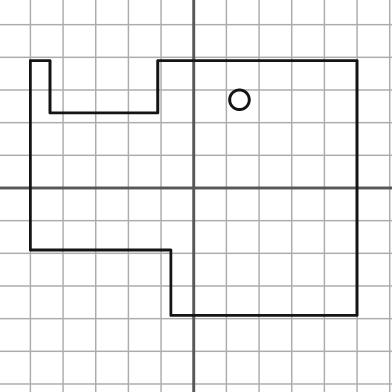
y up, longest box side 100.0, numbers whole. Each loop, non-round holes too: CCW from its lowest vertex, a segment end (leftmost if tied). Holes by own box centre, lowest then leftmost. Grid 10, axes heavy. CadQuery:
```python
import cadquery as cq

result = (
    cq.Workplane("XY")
    .moveTo(-7.0, -39.0)
    .lineTo(50.0, -39.0)
    .lineTo(50.0, 39.0)
    .lineTo(-11.0, 39.0)
    .lineTo(-11.0, 23.0)
    .lineTo(-44.0, 23.0)
    .lineTo(-44.0, 39.0)
    .lineTo(-50.0, 39.0)
    .lineTo(-50.0, -19.0)
    .lineTo(-7.0, -19.0)
    .close()
    .moveTo(14.0, 27.0)
    .circle(3.0)
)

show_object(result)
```